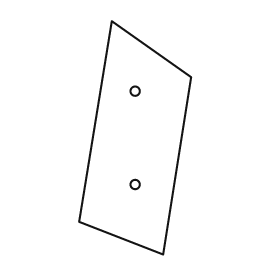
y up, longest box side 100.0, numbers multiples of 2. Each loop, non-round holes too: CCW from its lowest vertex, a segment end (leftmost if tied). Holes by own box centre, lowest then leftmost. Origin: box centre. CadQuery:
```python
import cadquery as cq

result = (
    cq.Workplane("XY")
    .moveTo(12.0, -50.0)
    .lineTo(24.0, 26.0)
    .lineTo(-10.0, 50.0)
    .lineTo(-24.0, -36.0)
    .close()
    .moveTo(0.0, -20.0)
    .circle(2.0)
    .moveTo(0.0, 20.0)
    .circle(2.0)
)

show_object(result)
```